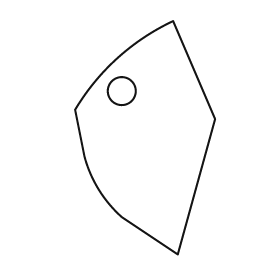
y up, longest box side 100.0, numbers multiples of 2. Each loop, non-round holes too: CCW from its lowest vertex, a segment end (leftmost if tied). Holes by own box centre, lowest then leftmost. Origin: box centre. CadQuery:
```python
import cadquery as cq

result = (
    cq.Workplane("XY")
    .moveTo(14.0, -50.0)
    .lineTo(30.0, 8.0)
    .lineTo(12.0, 50.0)
    .threePointArc((-12.0, 34.0), (-30.0, 12.0))
    .lineTo(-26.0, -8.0)
    .threePointArc((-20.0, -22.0), (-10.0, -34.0))
    .close()
    .moveTo(-10.0, 20.0)
    .circle(6.0)
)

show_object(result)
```